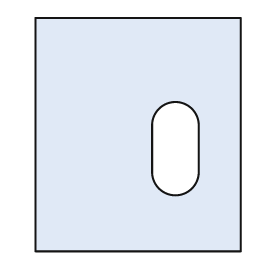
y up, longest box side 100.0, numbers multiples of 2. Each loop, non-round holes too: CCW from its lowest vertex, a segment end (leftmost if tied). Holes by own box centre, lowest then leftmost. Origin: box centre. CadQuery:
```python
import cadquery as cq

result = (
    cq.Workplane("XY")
    .moveTo(-44.0, -50.0)
    .lineTo(44.0, -50.0)
    .lineTo(44.0, 50.0)
    .lineTo(-44.0, 50.0)
    .close()
    .moveTo(6.0, -16.0)
    .threePointArc((16.0, -26.0), (26.0, -16.0))
    .lineTo(26.0, 4.0)
    .threePointArc((16.0, 14.0), (6.0, 4.0))
    .close()
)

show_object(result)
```